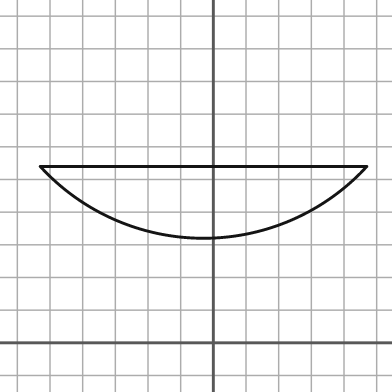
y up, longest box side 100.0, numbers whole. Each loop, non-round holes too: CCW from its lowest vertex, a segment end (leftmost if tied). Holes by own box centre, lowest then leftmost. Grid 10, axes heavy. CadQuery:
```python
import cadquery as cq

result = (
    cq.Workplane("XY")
    .moveTo(-53.0, 54.0)
    .threePointArc((-3.0, 32.0), (47.0, 54.0))
    .close()
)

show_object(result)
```